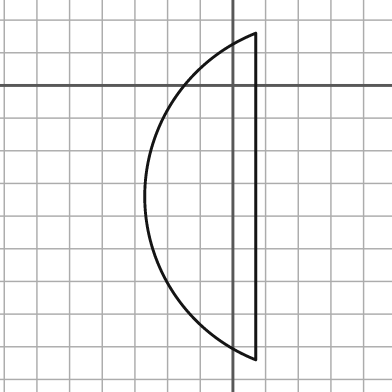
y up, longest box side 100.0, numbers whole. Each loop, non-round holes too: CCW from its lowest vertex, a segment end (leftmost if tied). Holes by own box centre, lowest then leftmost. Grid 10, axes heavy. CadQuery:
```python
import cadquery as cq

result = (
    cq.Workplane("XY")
    .moveTo(7.0, -84.0)
    .lineTo(7.0, 16.0)
    .threePointArc((-27.0, -34.0), (7.0, -84.0))
    .close()
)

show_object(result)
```